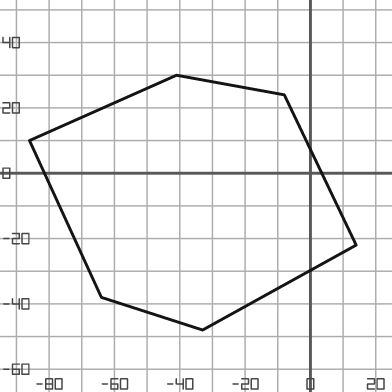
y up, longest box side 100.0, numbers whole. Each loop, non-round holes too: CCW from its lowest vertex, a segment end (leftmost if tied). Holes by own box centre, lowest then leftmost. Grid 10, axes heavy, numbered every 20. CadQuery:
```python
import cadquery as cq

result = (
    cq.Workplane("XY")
    .moveTo(-33.0, -48.0)
    .lineTo(14.0, -22.0)
    .lineTo(-8.0, 24.0)
    .lineTo(-41.0, 30.0)
    .lineTo(-86.0, 10.0)
    .lineTo(-64.0, -38.0)
    .close()
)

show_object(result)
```